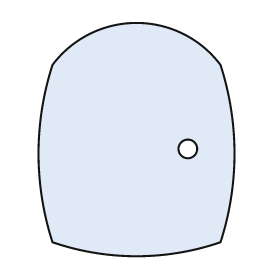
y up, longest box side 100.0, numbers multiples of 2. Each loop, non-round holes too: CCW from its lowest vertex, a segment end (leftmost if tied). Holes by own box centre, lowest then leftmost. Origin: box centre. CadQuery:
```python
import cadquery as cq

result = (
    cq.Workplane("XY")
    .moveTo(-36.0, -44.0)
    .threePointArc((0.0, -50.0), (36.0, -44.0))
    .threePointArc((42.0, -6.0), (36.0, 32.0))
    .threePointArc((0.0, 50.0), (-36.0, 32.0))
    .threePointArc((-42.0, -6.0), (-36.0, -44.0))
    .close()
    .moveTo(22.0, -4.0)
    .circle(4.0)
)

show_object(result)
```